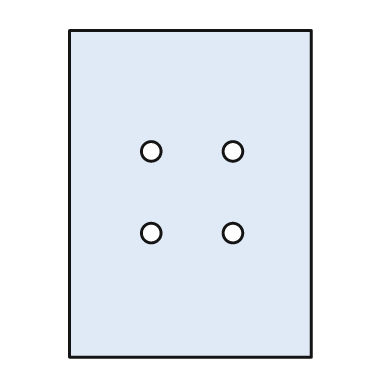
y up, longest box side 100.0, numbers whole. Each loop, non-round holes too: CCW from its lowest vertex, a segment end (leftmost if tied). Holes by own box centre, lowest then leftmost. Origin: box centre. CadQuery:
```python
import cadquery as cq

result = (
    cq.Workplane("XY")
    .moveTo(-37.0, -50.0)
    .lineTo(37.0, -50.0)
    .lineTo(37.0, 50.0)
    .lineTo(-37.0, 50.0)
    .close()
    .moveTo(-12.0, -12.0)
    .circle(3.0)
    .moveTo(13.0, -12.0)
    .circle(3.0)
    .moveTo(-12.0, 13.0)
    .circle(3.0)
    .moveTo(13.0, 13.0)
    .circle(3.0)
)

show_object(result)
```